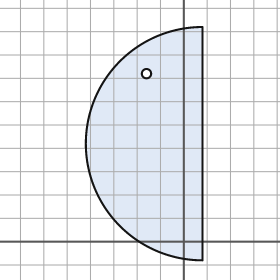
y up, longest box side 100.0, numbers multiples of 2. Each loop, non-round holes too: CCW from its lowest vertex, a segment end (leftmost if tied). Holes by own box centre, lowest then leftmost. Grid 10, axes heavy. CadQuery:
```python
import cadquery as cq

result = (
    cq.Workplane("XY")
    .moveTo(8.0, -8.0)
    .lineTo(8.0, 92.0)
    .threePointArc((-42.0, 42.0), (8.0, -8.0))
    .close()
    .moveTo(-16.0, 72.0)
    .circle(2.0)
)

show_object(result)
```